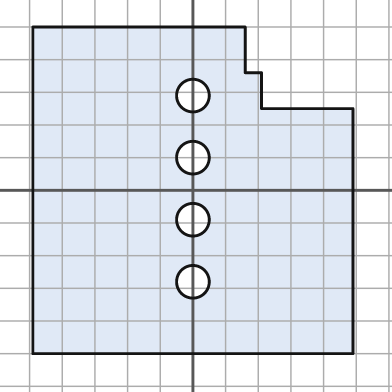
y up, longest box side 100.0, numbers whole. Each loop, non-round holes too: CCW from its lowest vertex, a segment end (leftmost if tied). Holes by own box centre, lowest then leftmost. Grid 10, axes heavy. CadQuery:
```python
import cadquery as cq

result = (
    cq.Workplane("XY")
    .moveTo(-49.0, -50.0)
    .lineTo(49.0, -50.0)
    .lineTo(49.0, 25.0)
    .lineTo(21.0, 25.0)
    .lineTo(21.0, 36.0)
    .lineTo(16.0, 36.0)
    .lineTo(16.0, 50.0)
    .lineTo(-49.0, 50.0)
    .close()
    .moveTo(0.0, -28.0)
    .circle(5.0)
    .moveTo(0.0, -9.0)
    .circle(5.0)
    .moveTo(0.0, 10.0)
    .circle(5.0)
    .moveTo(0.0, 29.0)
    .circle(5.0)
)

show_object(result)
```